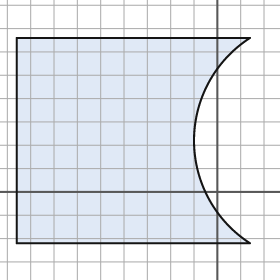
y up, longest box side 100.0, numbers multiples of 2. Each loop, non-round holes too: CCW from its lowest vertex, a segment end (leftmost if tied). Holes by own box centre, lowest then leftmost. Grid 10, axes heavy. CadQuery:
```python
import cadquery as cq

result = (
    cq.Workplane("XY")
    .moveTo(-86.0, -22.0)
    .lineTo(14.0, -22.0)
    .threePointArc((-10.0, 22.0), (14.0, 66.0))
    .lineTo(-86.0, 66.0)
    .close()
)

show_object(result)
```